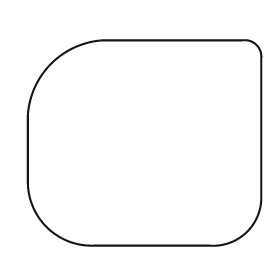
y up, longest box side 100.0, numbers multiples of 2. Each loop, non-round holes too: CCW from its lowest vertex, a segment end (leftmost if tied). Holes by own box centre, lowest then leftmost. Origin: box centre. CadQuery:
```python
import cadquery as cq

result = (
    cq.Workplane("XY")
    .moveTo(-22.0, -44.0)
    .lineTo(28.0, -44.0)
    .threePointArc((44.0, -38.0), (50.0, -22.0))
    .lineTo(50.0, 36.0)
    .threePointArc((48.0, 42.0), (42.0, 44.0))
    .lineTo(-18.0, 44.0)
    .threePointArc((-40.0, 34.0), (-50.0, 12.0))
    .lineTo(-50.0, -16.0)
    .threePointArc((-42.0, -36.0), (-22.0, -44.0))
    .close()
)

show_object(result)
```